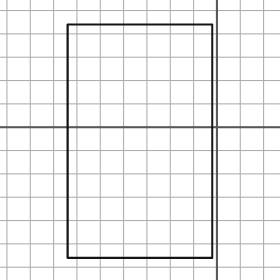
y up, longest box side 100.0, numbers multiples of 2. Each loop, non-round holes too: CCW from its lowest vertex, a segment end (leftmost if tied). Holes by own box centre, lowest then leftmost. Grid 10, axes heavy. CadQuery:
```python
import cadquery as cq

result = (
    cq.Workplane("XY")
    .moveTo(-64.0, -56.0)
    .lineTo(-2.0, -56.0)
    .lineTo(-2.0, 44.0)
    .lineTo(-64.0, 44.0)
    .close()
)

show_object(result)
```